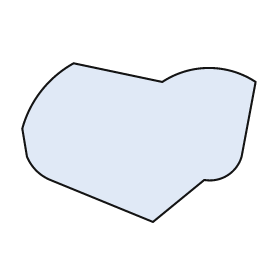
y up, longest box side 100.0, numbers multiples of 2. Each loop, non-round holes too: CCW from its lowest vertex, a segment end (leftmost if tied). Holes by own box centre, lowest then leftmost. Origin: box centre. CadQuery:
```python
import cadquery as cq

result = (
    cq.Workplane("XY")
    .moveTo(6.0, -34.0)
    .lineTo(28.0, -16.0)
    .threePointArc((38.0, -14.0), (44.0, -6.0))
    .lineTo(50.0, 26.0)
    .threePointArc((30.0, 32.0), (10.0, 26.0))
    .lineTo(-28.0, 34.0)
    .threePointArc((-42.0, 22.0), (-50.0, 6.0))
    .lineTo(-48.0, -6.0)
    .threePointArc((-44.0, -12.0), (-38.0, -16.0))
    .close()
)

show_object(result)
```